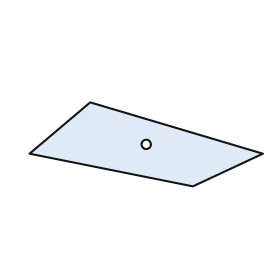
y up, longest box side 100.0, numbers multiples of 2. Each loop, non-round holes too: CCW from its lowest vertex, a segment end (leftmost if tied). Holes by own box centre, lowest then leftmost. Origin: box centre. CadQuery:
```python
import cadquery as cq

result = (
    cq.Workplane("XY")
    .moveTo(20.0, -18.0)
    .lineTo(50.0, -4.0)
    .lineTo(-24.0, 18.0)
    .lineTo(-50.0, -4.0)
    .close()
    .moveTo(0.0, 0.0)
    .circle(2.0)
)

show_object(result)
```